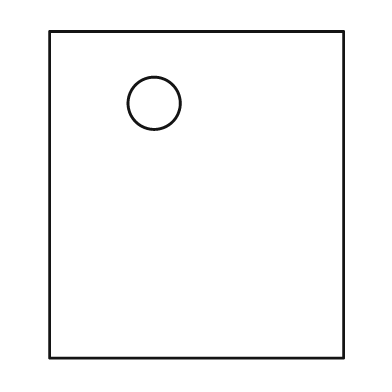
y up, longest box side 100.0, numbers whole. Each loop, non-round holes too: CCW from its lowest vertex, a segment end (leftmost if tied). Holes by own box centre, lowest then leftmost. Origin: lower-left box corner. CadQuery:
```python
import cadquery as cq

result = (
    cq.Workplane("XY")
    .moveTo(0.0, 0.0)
    .lineTo(90.0, 0.0)
    .lineTo(90.0, 100.0)
    .lineTo(0.0, 100.0)
    .close()
    .moveTo(32.0, 78.0)
    .circle(8.0)
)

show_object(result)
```